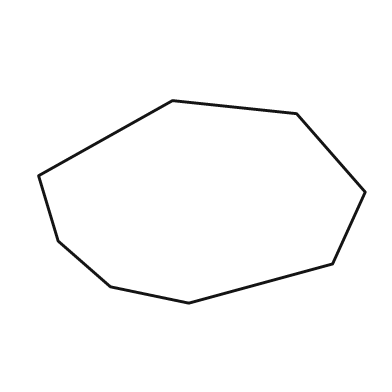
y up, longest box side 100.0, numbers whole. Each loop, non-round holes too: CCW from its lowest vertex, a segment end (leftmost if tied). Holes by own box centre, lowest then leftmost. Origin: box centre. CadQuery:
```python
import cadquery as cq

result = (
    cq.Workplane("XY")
    .moveTo(-4.0, -31.0)
    .lineTo(40.0, -19.0)
    .lineTo(50.0, 3.0)
    .lineTo(29.0, 27.0)
    .lineTo(-9.0, 31.0)
    .lineTo(-50.0, 8.0)
    .lineTo(-44.0, -12.0)
    .lineTo(-28.0, -26.0)
    .close()
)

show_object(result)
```